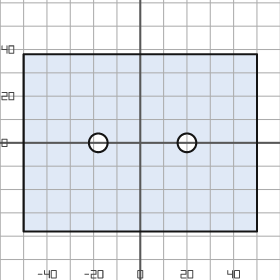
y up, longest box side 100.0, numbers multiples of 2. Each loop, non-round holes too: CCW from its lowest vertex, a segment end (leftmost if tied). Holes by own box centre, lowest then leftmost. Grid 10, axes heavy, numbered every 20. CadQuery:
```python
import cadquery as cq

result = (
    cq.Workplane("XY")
    .moveTo(-50.0, -38.0)
    .lineTo(50.0, -38.0)
    .lineTo(50.0, 38.0)
    .lineTo(-50.0, 38.0)
    .close()
    .moveTo(-18.0, 0.0)
    .circle(4.0)
    .moveTo(20.0, 0.0)
    .circle(4.0)
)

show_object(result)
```